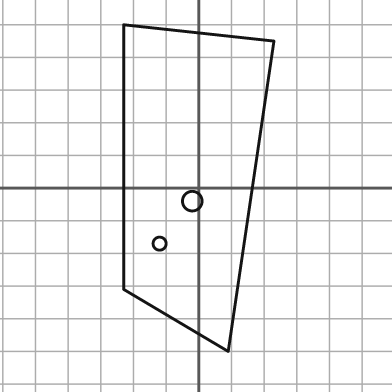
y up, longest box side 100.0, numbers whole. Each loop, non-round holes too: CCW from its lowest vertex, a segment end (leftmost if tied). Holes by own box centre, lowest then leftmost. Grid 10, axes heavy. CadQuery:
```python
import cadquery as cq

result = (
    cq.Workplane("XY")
    .moveTo(9.0, -50.0)
    .lineTo(23.0, 45.0)
    .lineTo(-23.0, 50.0)
    .lineTo(-23.0, -31.0)
    .close()
    .moveTo(-12.0, -17.0)
    .circle(2.0)
    .moveTo(-2.0, -4.0)
    .circle(3.0)
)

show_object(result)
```